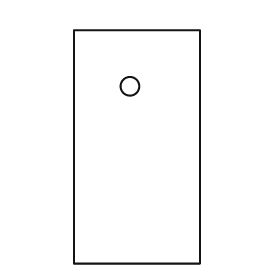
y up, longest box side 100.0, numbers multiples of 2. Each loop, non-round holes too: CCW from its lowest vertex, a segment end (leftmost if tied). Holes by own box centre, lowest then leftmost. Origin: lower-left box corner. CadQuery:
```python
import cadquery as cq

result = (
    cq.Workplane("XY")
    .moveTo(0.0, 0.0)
    .lineTo(54.0, 0.0)
    .lineTo(54.0, 100.0)
    .lineTo(0.0, 100.0)
    .close()
    .moveTo(24.0, 76.0)
    .circle(4.0)
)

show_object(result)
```